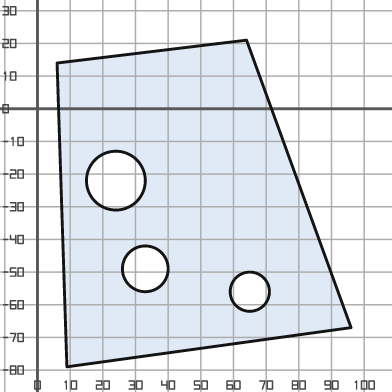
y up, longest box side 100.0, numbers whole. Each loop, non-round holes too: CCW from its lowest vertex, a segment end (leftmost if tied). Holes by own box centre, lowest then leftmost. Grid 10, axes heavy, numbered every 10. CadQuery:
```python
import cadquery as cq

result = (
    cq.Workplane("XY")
    .moveTo(9.0, -79.0)
    .lineTo(96.0, -67.0)
    .lineTo(64.0, 21.0)
    .lineTo(6.0, 14.0)
    .close()
    .moveTo(65.0, -56.0)
    .circle(6.0)
    .moveTo(33.0, -49.0)
    .circle(7.0)
    .moveTo(24.0, -22.0)
    .circle(9.0)
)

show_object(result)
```